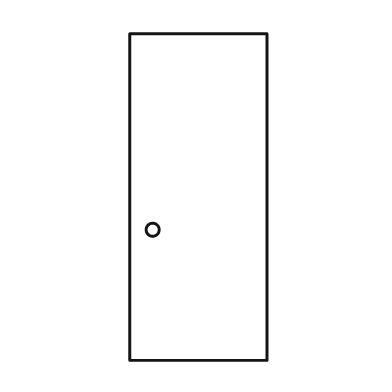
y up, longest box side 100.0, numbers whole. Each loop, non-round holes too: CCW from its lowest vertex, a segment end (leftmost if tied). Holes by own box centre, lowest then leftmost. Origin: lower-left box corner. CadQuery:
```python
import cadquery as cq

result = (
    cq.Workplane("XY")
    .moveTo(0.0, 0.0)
    .lineTo(42.0, 0.0)
    .lineTo(42.0, 100.0)
    .lineTo(0.0, 100.0)
    .close()
    .moveTo(7.0, 40.0)
    .circle(2.0)
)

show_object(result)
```